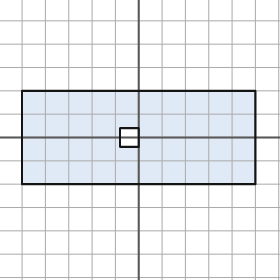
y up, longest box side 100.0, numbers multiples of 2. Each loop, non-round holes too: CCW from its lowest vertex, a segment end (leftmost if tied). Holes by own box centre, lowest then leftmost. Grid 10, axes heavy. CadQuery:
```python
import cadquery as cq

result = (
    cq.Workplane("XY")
    .moveTo(-50.0, -20.0)
    .lineTo(50.0, -20.0)
    .lineTo(50.0, 20.0)
    .lineTo(-50.0, 20.0)
    .close()
    .moveTo(-8.0, -4.0)
    .lineTo(0.0, -4.0)
    .lineTo(0.0, 4.0)
    .lineTo(-8.0, 4.0)
    .close()
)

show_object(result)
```